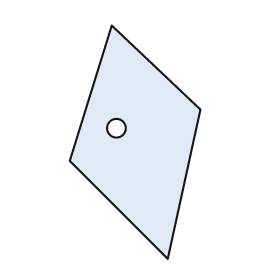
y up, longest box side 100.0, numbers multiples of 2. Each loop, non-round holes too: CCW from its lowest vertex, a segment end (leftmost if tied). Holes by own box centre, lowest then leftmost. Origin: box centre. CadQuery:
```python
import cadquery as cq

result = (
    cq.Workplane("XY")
    .moveTo(14.0, -50.0)
    .lineTo(28.0, 14.0)
    .lineTo(-10.0, 50.0)
    .lineTo(-28.0, -8.0)
    .close()
    .moveTo(-8.0, 6.0)
    .circle(4.0)
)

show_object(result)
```